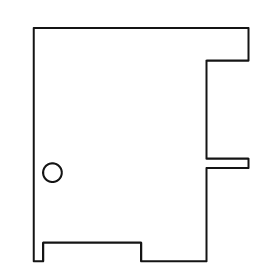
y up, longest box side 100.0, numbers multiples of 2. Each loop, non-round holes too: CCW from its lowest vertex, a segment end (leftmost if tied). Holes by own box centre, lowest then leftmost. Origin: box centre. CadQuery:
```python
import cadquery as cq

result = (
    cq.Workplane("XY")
    .moveTo(-46.0, -50.0)
    .lineTo(-42.0, -50.0)
    .lineTo(-42.0, -42.0)
    .lineTo(0.0, -42.0)
    .lineTo(0.0, -50.0)
    .lineTo(28.0, -50.0)
    .lineTo(28.0, -10.0)
    .lineTo(46.0, -10.0)
    .lineTo(46.0, -6.0)
    .lineTo(28.0, -6.0)
    .lineTo(28.0, 36.0)
    .lineTo(46.0, 36.0)
    .lineTo(46.0, 50.0)
    .lineTo(-46.0, 50.0)
    .close()
    .moveTo(-38.0, -12.0)
    .circle(4.0)
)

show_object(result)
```